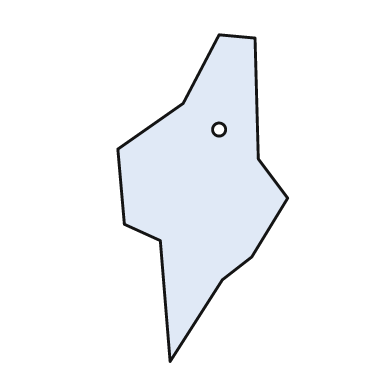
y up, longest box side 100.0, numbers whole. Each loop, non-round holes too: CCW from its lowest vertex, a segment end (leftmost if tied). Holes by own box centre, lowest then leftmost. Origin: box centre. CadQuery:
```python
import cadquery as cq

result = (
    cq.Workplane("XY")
    .moveTo(-10.0, -50.0)
    .lineTo(6.0, -25.0)
    .lineTo(15.0, -18.0)
    .lineTo(26.0, 0.0)
    .lineTo(17.0, 12.0)
    .lineTo(16.0, 49.0)
    .lineTo(5.0, 50.0)
    .lineTo(-6.0, 29.0)
    .lineTo(-26.0, 15.0)
    .lineTo(-24.0, -8.0)
    .lineTo(-13.0, -13.0)
    .close()
    .moveTo(5.0, 21.0)
    .circle(2.0)
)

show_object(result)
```